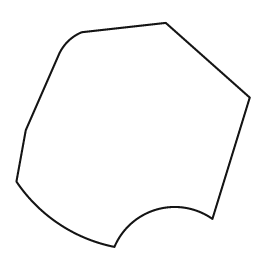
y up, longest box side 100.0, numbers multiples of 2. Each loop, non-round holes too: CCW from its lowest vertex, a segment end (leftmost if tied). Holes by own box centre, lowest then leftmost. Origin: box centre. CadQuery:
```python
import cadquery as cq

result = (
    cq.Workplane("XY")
    .moveTo(-8.0, -48.0)
    .threePointArc((10.0, -32.0), (34.0, -36.0))
    .lineTo(50.0, 16.0)
    .lineTo(14.0, 48.0)
    .lineTo(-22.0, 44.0)
    .threePointArc((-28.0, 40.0), (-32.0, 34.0))
    .lineTo(-46.0, 2.0)
    .lineTo(-50.0, -20.0)
    .threePointArc((-32.0, -38.0), (-8.0, -48.0))
    .close()
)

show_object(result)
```